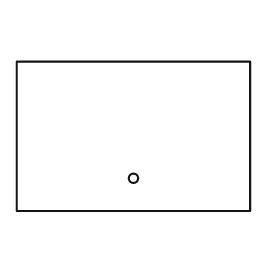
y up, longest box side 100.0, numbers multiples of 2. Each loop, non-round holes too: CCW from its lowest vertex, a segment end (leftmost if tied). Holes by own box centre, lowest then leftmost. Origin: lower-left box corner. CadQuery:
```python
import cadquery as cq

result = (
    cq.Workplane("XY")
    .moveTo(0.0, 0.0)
    .lineTo(100.0, 0.0)
    .lineTo(100.0, 64.0)
    .lineTo(0.0, 64.0)
    .close()
    .moveTo(50.0, 14.0)
    .circle(2.0)
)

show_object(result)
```